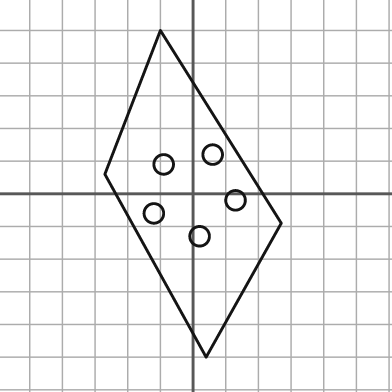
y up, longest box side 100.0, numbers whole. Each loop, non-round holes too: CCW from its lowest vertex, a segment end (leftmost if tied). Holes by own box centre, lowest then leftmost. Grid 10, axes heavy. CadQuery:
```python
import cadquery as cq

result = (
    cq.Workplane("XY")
    .moveTo(4.0, -50.0)
    .lineTo(27.0, -9.0)
    .lineTo(-10.0, 50.0)
    .lineTo(-27.0, 6.0)
    .close()
    .moveTo(2.0, -13.0)
    .circle(3.0)
    .moveTo(-12.0, -6.0)
    .circle(3.0)
    .moveTo(13.0, -2.0)
    .circle(3.0)
    .moveTo(-9.0, 9.0)
    .circle(3.0)
    .moveTo(6.0, 12.0)
    .circle(3.0)
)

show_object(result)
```